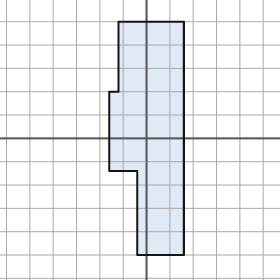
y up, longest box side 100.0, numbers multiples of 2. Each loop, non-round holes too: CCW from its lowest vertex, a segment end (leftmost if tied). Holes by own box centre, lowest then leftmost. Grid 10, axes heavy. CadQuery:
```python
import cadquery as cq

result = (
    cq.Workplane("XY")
    .moveTo(-4.0, -50.0)
    .lineTo(16.0, -50.0)
    .lineTo(16.0, 50.0)
    .lineTo(-12.0, 50.0)
    .lineTo(-12.0, 20.0)
    .lineTo(-16.0, 20.0)
    .lineTo(-16.0, -14.0)
    .lineTo(-4.0, -14.0)
    .close()
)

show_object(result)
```